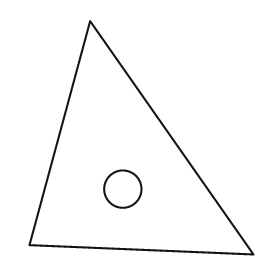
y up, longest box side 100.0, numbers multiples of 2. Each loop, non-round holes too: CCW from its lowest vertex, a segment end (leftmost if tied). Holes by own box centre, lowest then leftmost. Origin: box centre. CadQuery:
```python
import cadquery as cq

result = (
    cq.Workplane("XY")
    .moveTo(48.0, -50.0)
    .lineTo(-22.0, 50.0)
    .lineTo(-48.0, -46.0)
    .close()
    .moveTo(-8.0, -22.0)
    .circle(8.0)
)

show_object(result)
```